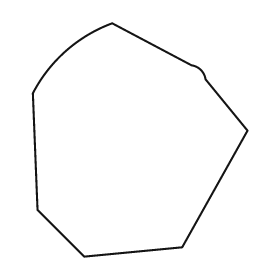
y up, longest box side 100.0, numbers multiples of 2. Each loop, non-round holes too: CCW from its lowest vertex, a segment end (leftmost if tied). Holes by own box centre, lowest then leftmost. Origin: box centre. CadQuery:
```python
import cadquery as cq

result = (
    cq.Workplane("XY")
    .moveTo(-24.0, -50.0)
    .lineTo(18.0, -46.0)
    .lineTo(46.0, 4.0)
    .lineTo(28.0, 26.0)
    .threePointArc((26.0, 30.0), (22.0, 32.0))
    .lineTo(-12.0, 50.0)
    .threePointArc((-32.0, 38.0), (-46.0, 20.0))
    .lineTo(-44.0, -30.0)
    .close()
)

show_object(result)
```